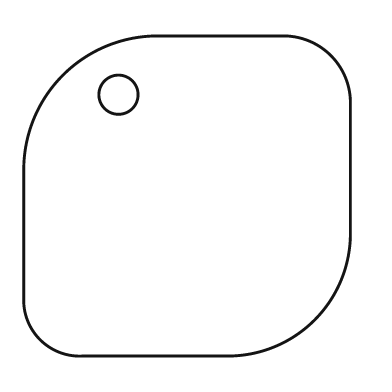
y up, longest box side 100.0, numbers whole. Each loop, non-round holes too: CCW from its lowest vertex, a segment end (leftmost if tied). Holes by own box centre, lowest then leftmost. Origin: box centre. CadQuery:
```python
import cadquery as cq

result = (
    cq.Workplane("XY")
    .moveTo(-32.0, -49.0)
    .lineTo(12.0, -49.0)
    .threePointArc((39.0, -38.0), (50.0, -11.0))
    .lineTo(50.0, 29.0)
    .threePointArc((44.0, 43.0), (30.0, 49.0))
    .lineTo(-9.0, 49.0)
    .threePointArc((-38.0, 37.0), (-50.0, 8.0))
    .lineTo(-50.0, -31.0)
    .threePointArc((-45.0, -44.0), (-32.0, -49.0))
    .close()
    .moveTo(-21.0, 31.0)
    .circle(6.0)
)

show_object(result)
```